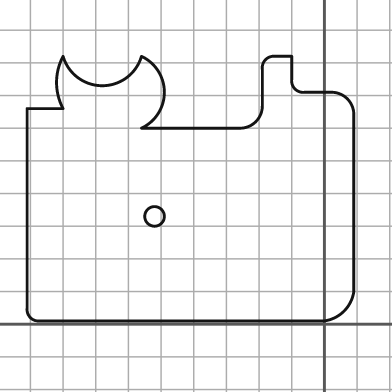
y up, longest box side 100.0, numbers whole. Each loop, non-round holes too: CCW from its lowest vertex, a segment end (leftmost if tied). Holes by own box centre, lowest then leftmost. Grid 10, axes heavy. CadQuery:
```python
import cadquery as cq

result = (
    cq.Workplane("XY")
    .moveTo(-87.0, 1.0)
    .lineTo(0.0, 1.0)
    .threePointArc((6.0, 4.0), (9.0, 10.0))
    .lineTo(9.0, 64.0)
    .threePointArc((7.0, 69.0), (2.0, 71.0))
    .lineTo(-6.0, 71.0)
    .threePointArc((-9.0, 72.0), (-10.0, 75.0))
    .lineTo(-10.0, 82.0)
    .lineTo(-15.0, 82.0)
    .threePointArc((-18.0, 81.0), (-19.0, 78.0))
    .lineTo(-19.0, 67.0)
    .threePointArc((-21.0, 62.0), (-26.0, 60.0))
    .lineTo(-56.0, 60.0)
    .threePointArc((-49.0, 71.0), (-56.0, 82.0))
    .threePointArc((-68.0, 73.0), (-80.0, 82.0))
    .threePointArc((-82.0, 74.0), (-80.0, 66.0))
    .lineTo(-91.0, 66.0)
    .lineTo(-91.0, 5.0)
    .threePointArc((-90.0, 2.0), (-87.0, 1.0))
    .close()
    .moveTo(-52.0, 33.0)
    .circle(3.0)
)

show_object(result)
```